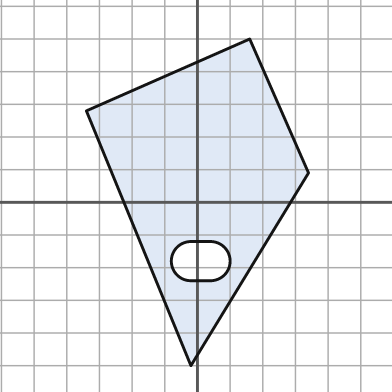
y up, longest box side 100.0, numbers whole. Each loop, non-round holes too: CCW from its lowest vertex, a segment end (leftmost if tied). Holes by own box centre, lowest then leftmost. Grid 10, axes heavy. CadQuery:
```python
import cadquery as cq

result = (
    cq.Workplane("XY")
    .moveTo(-2.0, -50.0)
    .lineTo(34.0, 9.0)
    .lineTo(16.0, 50.0)
    .lineTo(-34.0, 28.0)
    .close()
    .moveTo(-2.0, -24.0)
    .lineTo(4.0, -24.0)
    .threePointArc((10.0, -18.0), (4.0, -12.0))
    .lineTo(-2.0, -12.0)
    .threePointArc((-8.0, -18.0), (-2.0, -24.0))
    .close()
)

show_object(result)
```